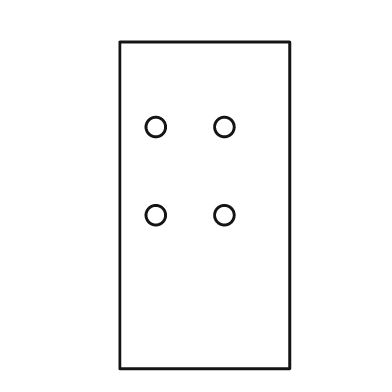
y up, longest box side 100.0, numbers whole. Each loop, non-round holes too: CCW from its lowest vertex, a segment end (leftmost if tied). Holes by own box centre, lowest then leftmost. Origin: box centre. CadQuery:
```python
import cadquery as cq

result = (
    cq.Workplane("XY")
    .moveTo(-26.0, -50.0)
    .lineTo(26.0, -50.0)
    .lineTo(26.0, 50.0)
    .lineTo(-26.0, 50.0)
    .close()
    .moveTo(-15.0, -3.0)
    .circle(3.0)
    .moveTo(6.0, -3.0)
    .circle(3.0)
    .moveTo(-15.0, 24.0)
    .circle(3.0)
    .moveTo(6.0, 24.0)
    .circle(3.0)
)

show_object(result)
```